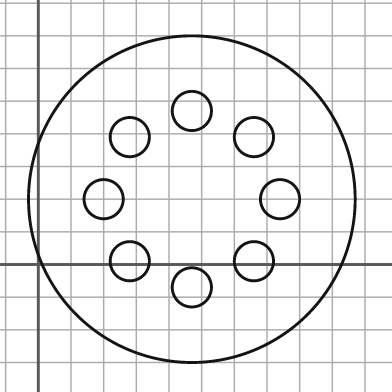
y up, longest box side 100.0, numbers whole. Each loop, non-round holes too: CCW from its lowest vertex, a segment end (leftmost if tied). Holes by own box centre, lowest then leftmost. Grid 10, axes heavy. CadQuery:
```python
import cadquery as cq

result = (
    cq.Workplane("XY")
    .moveTo(47.0, 20.0)
    .circle(50.0)
    .moveTo(47.0, -7.0)
    .circle(6.0)
    .moveTo(28.0, 1.0)
    .circle(6.0)
    .moveTo(66.0, 1.0)
    .circle(6.0)
    .moveTo(20.0, 20.0)
    .circle(6.0)
    .moveTo(74.0, 20.0)
    .circle(6.0)
    .moveTo(28.0, 39.0)
    .circle(6.0)
    .moveTo(66.0, 39.0)
    .circle(6.0)
    .moveTo(47.0, 47.0)
    .circle(6.0)
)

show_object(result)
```